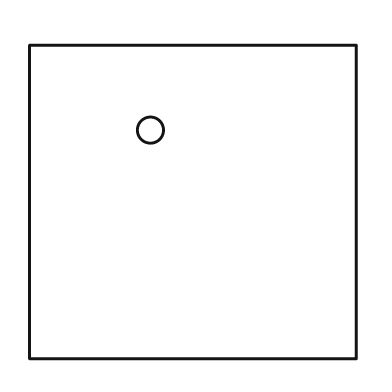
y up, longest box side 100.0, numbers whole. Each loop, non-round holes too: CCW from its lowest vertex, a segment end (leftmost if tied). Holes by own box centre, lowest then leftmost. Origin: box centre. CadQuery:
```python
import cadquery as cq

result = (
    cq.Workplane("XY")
    .moveTo(-50.0, -48.0)
    .lineTo(50.0, -48.0)
    .lineTo(50.0, 48.0)
    .lineTo(-50.0, 48.0)
    .close()
    .moveTo(-13.0, 22.0)
    .circle(4.0)
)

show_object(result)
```